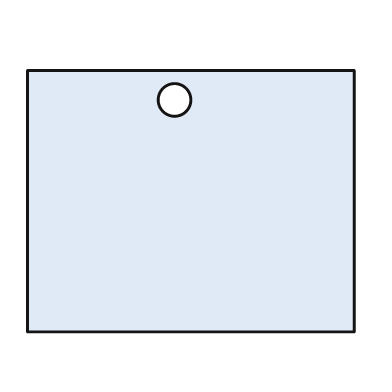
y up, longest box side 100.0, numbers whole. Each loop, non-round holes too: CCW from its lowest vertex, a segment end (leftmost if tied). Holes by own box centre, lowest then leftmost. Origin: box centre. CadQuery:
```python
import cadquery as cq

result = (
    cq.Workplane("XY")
    .moveTo(-50.0, -40.0)
    .lineTo(50.0, -40.0)
    .lineTo(50.0, 40.0)
    .lineTo(-50.0, 40.0)
    .close()
    .moveTo(-5.0, 31.0)
    .circle(5.0)
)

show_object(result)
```